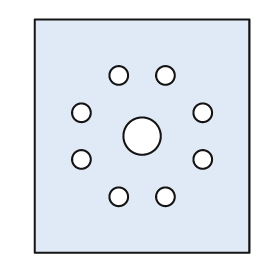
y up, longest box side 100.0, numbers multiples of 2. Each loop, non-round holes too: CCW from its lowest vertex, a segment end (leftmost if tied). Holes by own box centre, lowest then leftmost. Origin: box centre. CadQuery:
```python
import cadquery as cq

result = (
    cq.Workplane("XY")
    .moveTo(-46.0, -50.0)
    .lineTo(46.0, -50.0)
    .lineTo(46.0, 50.0)
    .lineTo(-46.0, 50.0)
    .close()
    .moveTo(-10.0, -26.0)
    .circle(4.0)
    .moveTo(10.0, -26.0)
    .circle(4.0)
    .moveTo(-26.0, -10.0)
    .circle(4.0)
    .moveTo(26.0, -10.0)
    .circle(4.0)
    .moveTo(0.0, 0.0)
    .circle(8.0)
    .moveTo(-26.0, 10.0)
    .circle(4.0)
    .moveTo(26.0, 10.0)
    .circle(4.0)
    .moveTo(-10.0, 26.0)
    .circle(4.0)
    .moveTo(10.0, 26.0)
    .circle(4.0)
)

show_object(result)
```